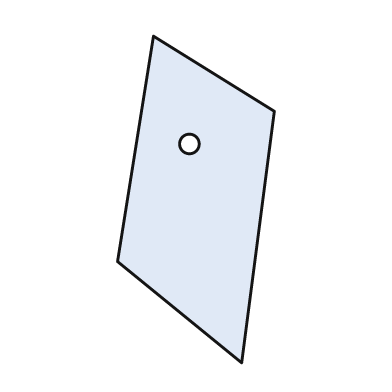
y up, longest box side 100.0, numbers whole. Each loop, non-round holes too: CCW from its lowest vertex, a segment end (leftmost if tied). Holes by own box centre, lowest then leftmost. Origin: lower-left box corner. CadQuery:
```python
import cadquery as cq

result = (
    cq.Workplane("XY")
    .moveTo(38.0, 0.0)
    .lineTo(48.0, 77.0)
    .lineTo(11.0, 100.0)
    .lineTo(0.0, 31.0)
    .close()
    .moveTo(22.0, 67.0)
    .circle(3.0)
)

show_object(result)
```